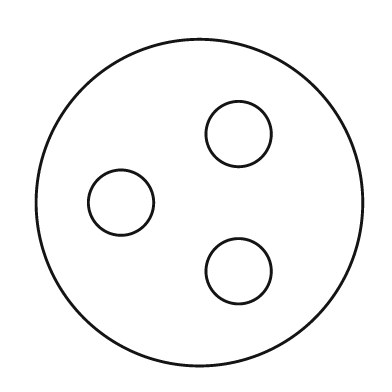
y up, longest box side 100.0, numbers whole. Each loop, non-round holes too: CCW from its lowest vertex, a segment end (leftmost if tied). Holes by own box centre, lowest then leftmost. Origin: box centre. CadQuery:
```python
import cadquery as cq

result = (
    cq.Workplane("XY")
    .moveTo(0.0, 0.0)
    .circle(50.0)
    .moveTo(12.0, -21.0)
    .circle(10.0)
    .moveTo(-24.0, 0.0)
    .circle(10.0)
    .moveTo(12.0, 21.0)
    .circle(10.0)
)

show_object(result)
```